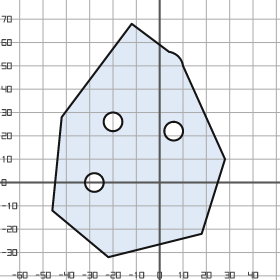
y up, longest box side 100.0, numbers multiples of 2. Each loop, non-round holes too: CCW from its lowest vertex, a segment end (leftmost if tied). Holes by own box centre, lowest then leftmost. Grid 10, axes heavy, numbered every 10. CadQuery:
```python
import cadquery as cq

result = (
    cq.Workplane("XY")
    .moveTo(-22.0, -32.0)
    .lineTo(18.0, -22.0)
    .lineTo(28.0, 10.0)
    .lineTo(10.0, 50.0)
    .threePointArc((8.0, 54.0), (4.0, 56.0))
    .lineTo(-12.0, 68.0)
    .lineTo(-42.0, 28.0)
    .lineTo(-46.0, -12.0)
    .close()
    .moveTo(-28.0, 0.0)
    .circle(4.0)
    .moveTo(6.0, 22.0)
    .circle(4.0)
    .moveTo(-20.0, 26.0)
    .circle(4.0)
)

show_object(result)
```